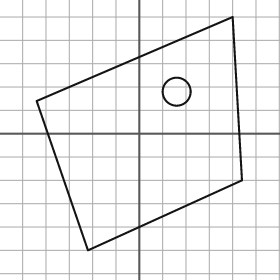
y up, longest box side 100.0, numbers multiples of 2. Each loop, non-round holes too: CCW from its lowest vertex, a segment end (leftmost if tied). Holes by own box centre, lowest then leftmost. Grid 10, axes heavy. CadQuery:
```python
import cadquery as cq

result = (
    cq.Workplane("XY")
    .moveTo(-22.0, -50.0)
    .lineTo(44.0, -20.0)
    .lineTo(40.0, 50.0)
    .lineTo(-44.0, 14.0)
    .close()
    .moveTo(16.0, 18.0)
    .circle(6.0)
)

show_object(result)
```